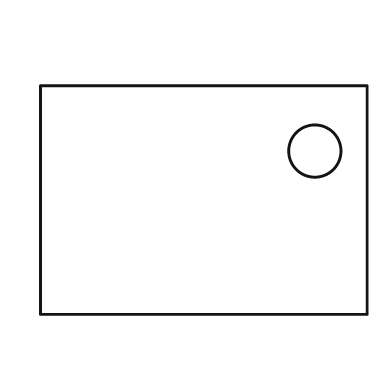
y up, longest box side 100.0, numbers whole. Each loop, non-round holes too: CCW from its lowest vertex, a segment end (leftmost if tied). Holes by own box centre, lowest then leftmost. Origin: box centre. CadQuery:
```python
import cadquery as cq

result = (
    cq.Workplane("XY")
    .moveTo(-50.0, -35.0)
    .lineTo(50.0, -35.0)
    .lineTo(50.0, 35.0)
    .lineTo(-50.0, 35.0)
    .close()
    .moveTo(34.0, 15.0)
    .circle(8.0)
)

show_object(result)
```